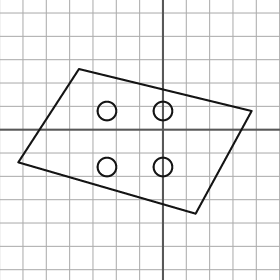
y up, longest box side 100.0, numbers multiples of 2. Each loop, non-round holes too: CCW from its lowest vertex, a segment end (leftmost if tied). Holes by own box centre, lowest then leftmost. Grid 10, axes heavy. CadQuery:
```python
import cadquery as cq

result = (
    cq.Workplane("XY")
    .moveTo(14.0, -36.0)
    .lineTo(38.0, 8.0)
    .lineTo(-36.0, 26.0)
    .lineTo(-62.0, -14.0)
    .close()
    .moveTo(-24.0, -16.0)
    .circle(4.0)
    .moveTo(0.0, -16.0)
    .circle(4.0)
    .moveTo(-24.0, 8.0)
    .circle(4.0)
    .moveTo(0.0, 8.0)
    .circle(4.0)
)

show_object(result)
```